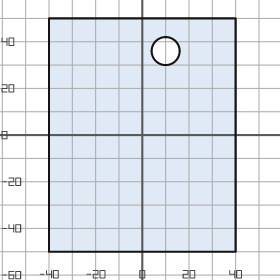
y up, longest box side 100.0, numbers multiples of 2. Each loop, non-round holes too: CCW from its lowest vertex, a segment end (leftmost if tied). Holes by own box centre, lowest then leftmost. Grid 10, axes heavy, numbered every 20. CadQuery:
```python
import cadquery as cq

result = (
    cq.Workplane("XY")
    .moveTo(-40.0, -50.0)
    .lineTo(40.0, -50.0)
    .lineTo(40.0, 50.0)
    .lineTo(-40.0, 50.0)
    .close()
    .moveTo(10.0, 36.0)
    .circle(6.0)
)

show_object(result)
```